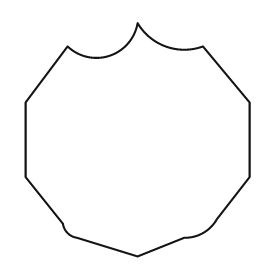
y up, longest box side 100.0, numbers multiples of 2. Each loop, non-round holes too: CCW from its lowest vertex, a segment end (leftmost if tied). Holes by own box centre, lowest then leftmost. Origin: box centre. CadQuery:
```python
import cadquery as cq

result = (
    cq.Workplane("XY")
    .moveTo(0.0, -50.0)
    .lineTo(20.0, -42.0)
    .threePointArc((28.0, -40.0), (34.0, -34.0))
    .lineTo(48.0, -16.0)
    .lineTo(48.0, 16.0)
    .lineTo(28.0, 40.0)
    .threePointArc((12.0, 40.0), (0.0, 50.0))
    .threePointArc((-12.0, 36.0), (-30.0, 40.0))
    .lineTo(-48.0, 16.0)
    .lineTo(-48.0, -16.0)
    .lineTo(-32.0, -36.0)
    .threePointArc((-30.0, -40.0), (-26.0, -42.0))
    .close()
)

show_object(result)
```